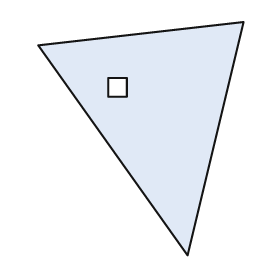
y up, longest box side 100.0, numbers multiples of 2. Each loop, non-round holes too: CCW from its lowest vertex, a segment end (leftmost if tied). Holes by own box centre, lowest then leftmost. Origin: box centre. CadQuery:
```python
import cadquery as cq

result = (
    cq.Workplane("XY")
    .moveTo(20.0, -50.0)
    .lineTo(44.0, 50.0)
    .lineTo(-44.0, 40.0)
    .close()
    .moveTo(-14.0, 18.0)
    .lineTo(-6.0, 18.0)
    .lineTo(-6.0, 26.0)
    .lineTo(-14.0, 26.0)
    .close()
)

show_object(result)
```